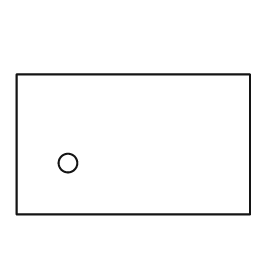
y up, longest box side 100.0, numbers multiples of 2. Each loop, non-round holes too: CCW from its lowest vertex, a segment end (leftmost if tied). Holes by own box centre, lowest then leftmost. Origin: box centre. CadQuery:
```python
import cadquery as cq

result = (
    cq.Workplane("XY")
    .moveTo(-50.0, -30.0)
    .lineTo(50.0, -30.0)
    .lineTo(50.0, 30.0)
    .lineTo(-50.0, 30.0)
    .close()
    .moveTo(-28.0, -8.0)
    .circle(4.0)
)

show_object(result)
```